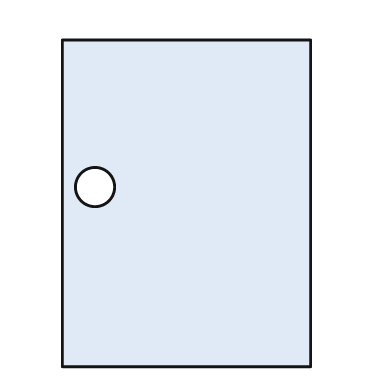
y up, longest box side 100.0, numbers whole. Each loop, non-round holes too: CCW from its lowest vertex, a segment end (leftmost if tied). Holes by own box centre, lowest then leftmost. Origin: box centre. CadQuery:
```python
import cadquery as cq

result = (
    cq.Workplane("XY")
    .moveTo(-38.0, -50.0)
    .lineTo(38.0, -50.0)
    .lineTo(38.0, 50.0)
    .lineTo(-38.0, 50.0)
    .close()
    .moveTo(-28.0, 5.0)
    .circle(6.0)
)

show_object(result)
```